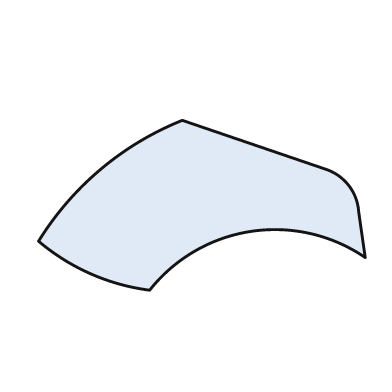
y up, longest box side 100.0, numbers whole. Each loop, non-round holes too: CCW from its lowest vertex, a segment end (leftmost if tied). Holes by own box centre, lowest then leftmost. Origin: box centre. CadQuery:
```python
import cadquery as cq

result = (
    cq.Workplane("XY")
    .moveTo(-16.0, -26.0)
    .threePointArc((15.0, -8.0), (50.0, -16.0))
    .lineTo(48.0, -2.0)
    .threePointArc((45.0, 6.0), (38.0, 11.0))
    .lineTo(-6.0, 26.0)
    .threePointArc((-31.0, 11.0), (-50.0, -11.0))
    .threePointArc((-34.0, -21.0), (-16.0, -26.0))
    .close()
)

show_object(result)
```